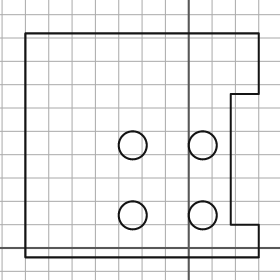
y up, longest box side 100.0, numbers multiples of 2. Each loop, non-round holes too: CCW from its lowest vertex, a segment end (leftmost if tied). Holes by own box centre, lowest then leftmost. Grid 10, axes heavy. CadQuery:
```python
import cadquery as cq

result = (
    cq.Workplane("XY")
    .moveTo(-70.0, -4.0)
    .lineTo(30.0, -4.0)
    .lineTo(30.0, 10.0)
    .lineTo(18.0, 10.0)
    .lineTo(18.0, 66.0)
    .lineTo(30.0, 66.0)
    .lineTo(30.0, 92.0)
    .lineTo(-70.0, 92.0)
    .close()
    .moveTo(-24.0, 14.0)
    .circle(6.0)
    .moveTo(6.0, 14.0)
    .circle(6.0)
    .moveTo(-24.0, 44.0)
    .circle(6.0)
    .moveTo(6.0, 44.0)
    .circle(6.0)
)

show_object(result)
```